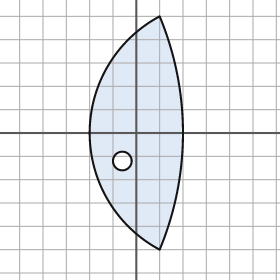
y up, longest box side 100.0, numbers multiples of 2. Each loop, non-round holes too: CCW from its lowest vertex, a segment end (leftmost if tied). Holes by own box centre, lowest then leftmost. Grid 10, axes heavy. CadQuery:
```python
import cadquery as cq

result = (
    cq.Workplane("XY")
    .moveTo(10.0, -50.0)
    .threePointArc((20.0, 0.0), (10.0, 50.0))
    .threePointArc((-20.0, 0.0), (10.0, -50.0))
    .close()
    .moveTo(-6.0, -12.0)
    .circle(4.0)
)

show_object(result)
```